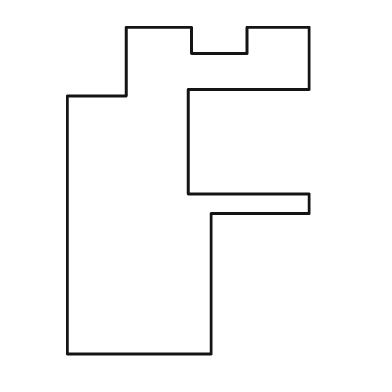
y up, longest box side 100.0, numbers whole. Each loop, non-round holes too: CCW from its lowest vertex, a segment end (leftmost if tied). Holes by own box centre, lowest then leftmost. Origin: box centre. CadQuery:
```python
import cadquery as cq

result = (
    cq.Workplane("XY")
    .moveTo(-37.0, -50.0)
    .lineTo(7.0, -50.0)
    .lineTo(7.0, -7.0)
    .lineTo(37.0, -7.0)
    .lineTo(37.0, -1.0)
    .lineTo(0.0, -1.0)
    .lineTo(0.0, 31.0)
    .lineTo(37.0, 31.0)
    .lineTo(37.0, 50.0)
    .lineTo(18.0, 50.0)
    .lineTo(18.0, 42.0)
    .lineTo(1.0, 42.0)
    .lineTo(1.0, 50.0)
    .lineTo(-19.0, 50.0)
    .lineTo(-19.0, 29.0)
    .lineTo(-37.0, 29.0)
    .close()
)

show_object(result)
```